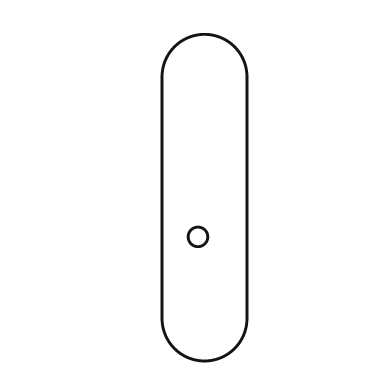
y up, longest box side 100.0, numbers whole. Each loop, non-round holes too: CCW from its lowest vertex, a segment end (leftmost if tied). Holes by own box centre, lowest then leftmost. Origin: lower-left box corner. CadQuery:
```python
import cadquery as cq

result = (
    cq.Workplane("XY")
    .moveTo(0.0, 13.0)
    .threePointArc((13.0, 0.0), (26.0, 13.0))
    .lineTo(26.0, 87.0)
    .threePointArc((13.0, 100.0), (0.0, 87.0))
    .close()
    .moveTo(11.0, 38.0)
    .circle(3.0)
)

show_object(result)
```